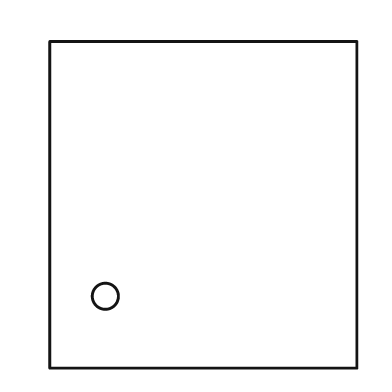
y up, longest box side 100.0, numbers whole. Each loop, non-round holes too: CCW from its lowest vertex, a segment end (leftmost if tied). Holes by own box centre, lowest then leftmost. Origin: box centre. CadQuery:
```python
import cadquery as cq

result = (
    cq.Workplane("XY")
    .moveTo(-47.0, -50.0)
    .lineTo(47.0, -50.0)
    .lineTo(47.0, 50.0)
    .lineTo(-47.0, 50.0)
    .close()
    .moveTo(-30.0, -28.0)
    .circle(4.0)
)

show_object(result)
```